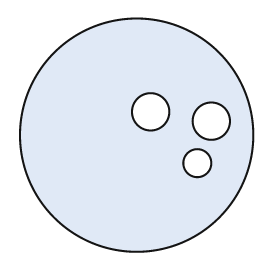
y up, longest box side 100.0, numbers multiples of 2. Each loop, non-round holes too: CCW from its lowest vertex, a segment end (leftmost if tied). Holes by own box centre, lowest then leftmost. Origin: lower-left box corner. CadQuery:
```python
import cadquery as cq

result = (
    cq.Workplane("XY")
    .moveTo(50.0, 50.0)
    .circle(50.0)
    .moveTo(76.0, 38.0)
    .circle(6.0)
    .moveTo(82.0, 56.0)
    .circle(8.0)
    .moveTo(56.0, 60.0)
    .circle(8.0)
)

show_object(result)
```